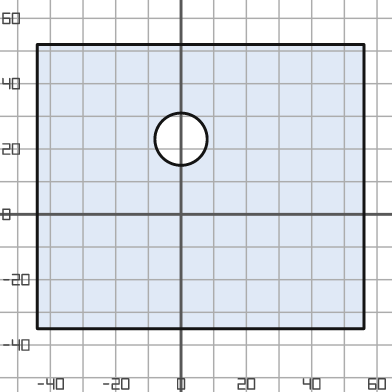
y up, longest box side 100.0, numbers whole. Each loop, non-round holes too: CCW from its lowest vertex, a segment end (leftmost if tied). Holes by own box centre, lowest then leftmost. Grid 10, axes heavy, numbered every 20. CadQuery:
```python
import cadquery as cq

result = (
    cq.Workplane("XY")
    .moveTo(-44.0, -35.0)
    .lineTo(56.0, -35.0)
    .lineTo(56.0, 52.0)
    .lineTo(-44.0, 52.0)
    .close()
    .moveTo(0.0, 23.0)
    .circle(8.0)
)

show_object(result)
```